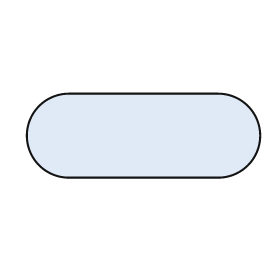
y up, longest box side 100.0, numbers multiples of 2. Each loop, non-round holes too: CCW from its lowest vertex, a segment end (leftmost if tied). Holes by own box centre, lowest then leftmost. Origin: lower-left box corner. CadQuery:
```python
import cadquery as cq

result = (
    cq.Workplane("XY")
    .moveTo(18.0, 0.0)
    .lineTo(82.0, 0.0)
    .threePointArc((100.0, 18.0), (82.0, 36.0))
    .lineTo(18.0, 36.0)
    .threePointArc((0.0, 18.0), (18.0, 0.0))
    .close()
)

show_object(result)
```